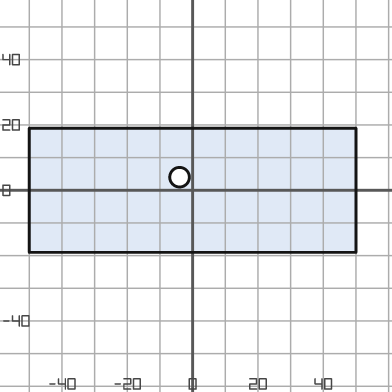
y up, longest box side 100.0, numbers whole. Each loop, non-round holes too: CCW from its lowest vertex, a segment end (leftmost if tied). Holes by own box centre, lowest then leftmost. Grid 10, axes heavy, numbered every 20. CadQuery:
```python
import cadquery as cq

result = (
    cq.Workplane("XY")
    .moveTo(-50.0, -19.0)
    .lineTo(50.0, -19.0)
    .lineTo(50.0, 19.0)
    .lineTo(-50.0, 19.0)
    .close()
    .moveTo(-4.0, 4.0)
    .circle(3.0)
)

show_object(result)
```